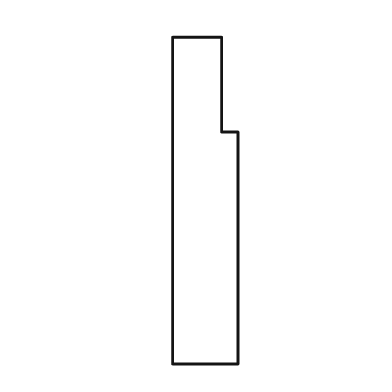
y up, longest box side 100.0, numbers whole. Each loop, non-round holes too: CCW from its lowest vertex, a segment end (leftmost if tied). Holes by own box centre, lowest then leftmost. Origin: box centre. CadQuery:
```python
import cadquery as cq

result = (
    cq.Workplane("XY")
    .moveTo(-10.0, -50.0)
    .lineTo(10.0, -50.0)
    .lineTo(10.0, 21.0)
    .lineTo(5.0, 21.0)
    .lineTo(5.0, 50.0)
    .lineTo(-10.0, 50.0)
    .close()
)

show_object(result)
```